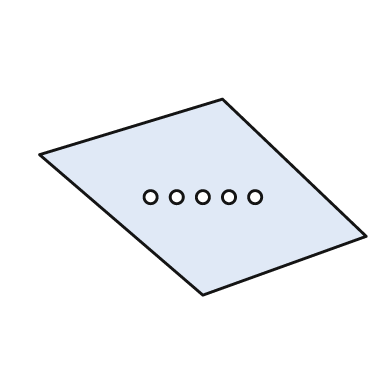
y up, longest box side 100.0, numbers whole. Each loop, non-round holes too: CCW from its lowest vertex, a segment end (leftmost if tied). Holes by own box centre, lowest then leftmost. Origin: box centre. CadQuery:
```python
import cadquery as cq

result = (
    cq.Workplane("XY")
    .moveTo(0.0, -30.0)
    .lineTo(50.0, -12.0)
    .lineTo(6.0, 30.0)
    .lineTo(-50.0, 13.0)
    .close()
    .moveTo(-16.0, 0.0)
    .circle(2.0)
    .moveTo(-8.0, 0.0)
    .circle(2.0)
    .moveTo(0.0, 0.0)
    .circle(2.0)
    .moveTo(8.0, 0.0)
    .circle(2.0)
    .moveTo(16.0, 0.0)
    .circle(2.0)
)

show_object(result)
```